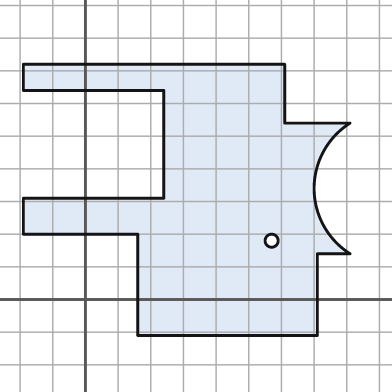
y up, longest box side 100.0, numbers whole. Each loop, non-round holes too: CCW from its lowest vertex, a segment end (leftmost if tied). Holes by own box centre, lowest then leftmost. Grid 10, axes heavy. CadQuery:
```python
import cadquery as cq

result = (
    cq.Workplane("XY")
    .moveTo(16.0, -11.0)
    .lineTo(71.0, -11.0)
    .lineTo(71.0, 14.0)
    .lineTo(81.0, 14.0)
    .threePointArc((70.0, 34.0), (81.0, 54.0))
    .lineTo(61.0, 54.0)
    .lineTo(61.0, 72.0)
    .lineTo(-19.0, 72.0)
    .lineTo(-19.0, 64.0)
    .lineTo(24.0, 64.0)
    .lineTo(24.0, 31.0)
    .lineTo(-19.0, 31.0)
    .lineTo(-19.0, 20.0)
    .lineTo(16.0, 20.0)
    .close()
    .moveTo(57.0, 18.0)
    .circle(2.0)
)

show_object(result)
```